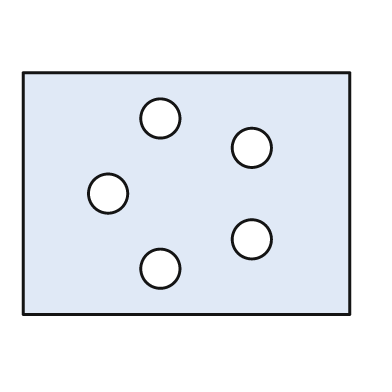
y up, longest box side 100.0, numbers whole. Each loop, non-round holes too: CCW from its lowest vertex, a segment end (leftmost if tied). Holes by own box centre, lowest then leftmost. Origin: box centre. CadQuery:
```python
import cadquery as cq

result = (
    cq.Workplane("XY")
    .moveTo(-50.0, -37.0)
    .lineTo(50.0, -37.0)
    .lineTo(50.0, 37.0)
    .lineTo(-50.0, 37.0)
    .close()
    .moveTo(-8.0, -23.0)
    .circle(6.0)
    .moveTo(20.0, -14.0)
    .circle(6.0)
    .moveTo(-24.0, 0.0)
    .circle(6.0)
    .moveTo(20.0, 14.0)
    .circle(6.0)
    .moveTo(-8.0, 23.0)
    .circle(6.0)
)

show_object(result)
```